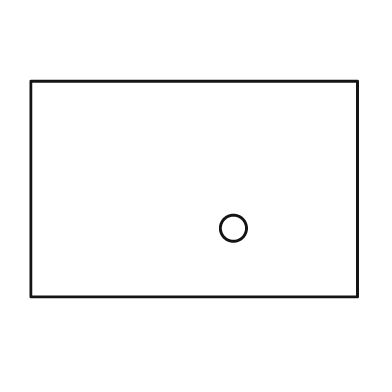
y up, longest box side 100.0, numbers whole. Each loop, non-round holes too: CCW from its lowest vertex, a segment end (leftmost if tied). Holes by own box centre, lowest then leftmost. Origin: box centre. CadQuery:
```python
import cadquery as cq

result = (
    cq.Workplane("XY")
    .moveTo(-50.0, -33.0)
    .lineTo(50.0, -33.0)
    .lineTo(50.0, 33.0)
    .lineTo(-50.0, 33.0)
    .close()
    .moveTo(12.0, -12.0)
    .circle(4.0)
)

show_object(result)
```